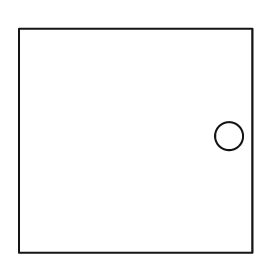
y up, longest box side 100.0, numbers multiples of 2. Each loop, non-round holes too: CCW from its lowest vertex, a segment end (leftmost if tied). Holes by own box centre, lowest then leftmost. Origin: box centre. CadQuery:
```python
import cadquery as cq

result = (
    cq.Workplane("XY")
    .moveTo(-50.0, -48.0)
    .lineTo(50.0, -48.0)
    .lineTo(50.0, 48.0)
    .lineTo(-50.0, 48.0)
    .close()
    .moveTo(40.0, 2.0)
    .circle(6.0)
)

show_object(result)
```